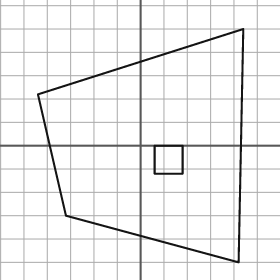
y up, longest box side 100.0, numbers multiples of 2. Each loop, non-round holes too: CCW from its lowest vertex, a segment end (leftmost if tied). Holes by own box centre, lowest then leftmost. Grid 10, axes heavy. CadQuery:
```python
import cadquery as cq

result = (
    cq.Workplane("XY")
    .moveTo(42.0, -50.0)
    .lineTo(44.0, 50.0)
    .lineTo(-44.0, 22.0)
    .lineTo(-32.0, -30.0)
    .close()
    .moveTo(6.0, -12.0)
    .lineTo(18.0, -12.0)
    .lineTo(18.0, 0.0)
    .lineTo(6.0, 0.0)
    .close()
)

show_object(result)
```